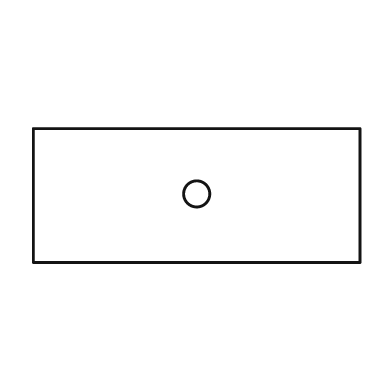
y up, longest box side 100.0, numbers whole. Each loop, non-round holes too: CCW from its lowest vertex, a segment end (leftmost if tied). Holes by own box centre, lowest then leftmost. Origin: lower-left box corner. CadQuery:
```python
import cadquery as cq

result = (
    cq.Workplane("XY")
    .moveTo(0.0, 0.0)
    .lineTo(100.0, 0.0)
    .lineTo(100.0, 41.0)
    .lineTo(0.0, 41.0)
    .close()
    .moveTo(50.0, 21.0)
    .circle(4.0)
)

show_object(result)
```